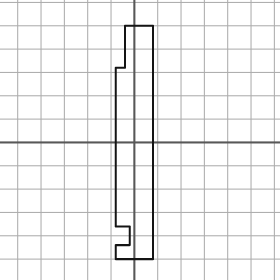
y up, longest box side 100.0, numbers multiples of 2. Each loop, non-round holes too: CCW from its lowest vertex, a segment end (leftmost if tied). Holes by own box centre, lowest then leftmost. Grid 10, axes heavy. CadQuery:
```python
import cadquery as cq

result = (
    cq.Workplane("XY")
    .moveTo(-8.0, -50.0)
    .lineTo(8.0, -50.0)
    .lineTo(8.0, 50.0)
    .lineTo(-4.0, 50.0)
    .lineTo(-4.0, 32.0)
    .lineTo(-8.0, 32.0)
    .lineTo(-8.0, -36.0)
    .lineTo(-2.0, -36.0)
    .lineTo(-2.0, -44.0)
    .lineTo(-8.0, -44.0)
    .close()
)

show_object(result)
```